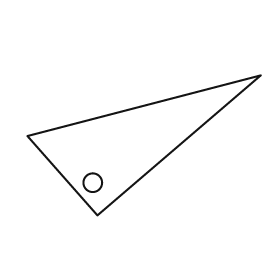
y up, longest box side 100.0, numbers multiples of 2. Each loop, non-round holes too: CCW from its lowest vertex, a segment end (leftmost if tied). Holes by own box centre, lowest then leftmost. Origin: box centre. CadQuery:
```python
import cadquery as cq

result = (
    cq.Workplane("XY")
    .moveTo(-20.0, -30.0)
    .lineTo(50.0, 30.0)
    .lineTo(-50.0, 4.0)
    .close()
    .moveTo(-22.0, -16.0)
    .circle(4.0)
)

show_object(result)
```